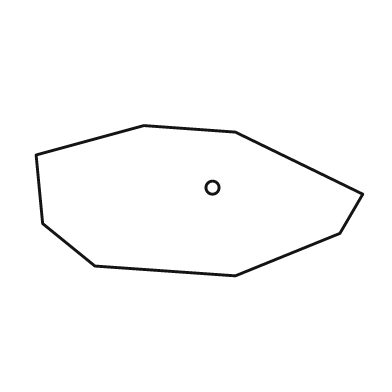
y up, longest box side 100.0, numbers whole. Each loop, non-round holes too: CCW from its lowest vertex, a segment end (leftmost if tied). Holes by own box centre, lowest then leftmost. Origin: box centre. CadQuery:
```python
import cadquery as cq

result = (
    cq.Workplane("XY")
    .moveTo(11.0, -23.0)
    .lineTo(43.0, -10.0)
    .lineTo(50.0, 2.0)
    .lineTo(11.0, 21.0)
    .lineTo(-17.0, 23.0)
    .lineTo(-50.0, 14.0)
    .lineTo(-48.0, -7.0)
    .lineTo(-32.0, -20.0)
    .close()
    .moveTo(4.0, 4.0)
    .circle(2.0)
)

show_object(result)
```